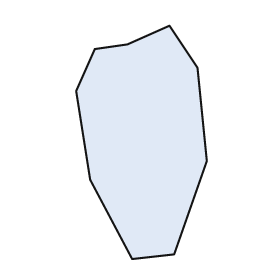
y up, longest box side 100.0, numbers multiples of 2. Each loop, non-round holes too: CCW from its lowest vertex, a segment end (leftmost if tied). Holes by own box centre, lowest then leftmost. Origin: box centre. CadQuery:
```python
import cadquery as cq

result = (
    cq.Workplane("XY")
    .moveTo(-4.0, -50.0)
    .lineTo(14.0, -48.0)
    .lineTo(28.0, -8.0)
    .lineTo(24.0, 32.0)
    .lineTo(12.0, 50.0)
    .lineTo(-6.0, 42.0)
    .lineTo(-20.0, 40.0)
    .lineTo(-28.0, 22.0)
    .lineTo(-22.0, -16.0)
    .close()
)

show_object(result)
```